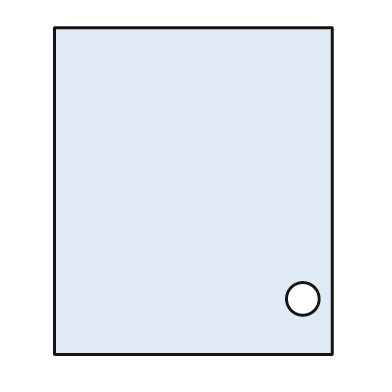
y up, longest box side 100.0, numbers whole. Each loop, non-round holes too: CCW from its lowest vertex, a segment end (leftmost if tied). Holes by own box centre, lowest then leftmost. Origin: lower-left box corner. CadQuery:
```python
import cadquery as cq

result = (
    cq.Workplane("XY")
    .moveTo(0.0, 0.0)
    .lineTo(85.0, 0.0)
    .lineTo(85.0, 100.0)
    .lineTo(0.0, 100.0)
    .close()
    .moveTo(76.0, 17.0)
    .circle(5.0)
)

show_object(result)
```